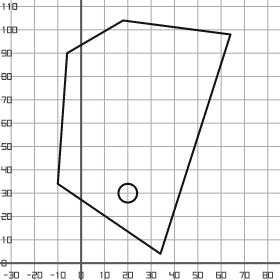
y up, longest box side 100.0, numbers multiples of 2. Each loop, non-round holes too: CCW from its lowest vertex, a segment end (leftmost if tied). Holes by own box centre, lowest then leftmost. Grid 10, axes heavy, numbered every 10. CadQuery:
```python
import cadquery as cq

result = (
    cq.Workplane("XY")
    .moveTo(34.0, 4.0)
    .lineTo(64.0, 98.0)
    .lineTo(18.0, 104.0)
    .lineTo(-6.0, 90.0)
    .lineTo(-10.0, 34.0)
    .close()
    .moveTo(20.0, 30.0)
    .circle(4.0)
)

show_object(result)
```